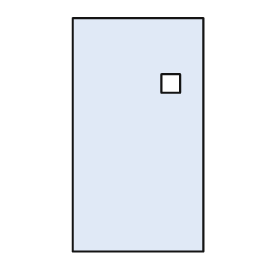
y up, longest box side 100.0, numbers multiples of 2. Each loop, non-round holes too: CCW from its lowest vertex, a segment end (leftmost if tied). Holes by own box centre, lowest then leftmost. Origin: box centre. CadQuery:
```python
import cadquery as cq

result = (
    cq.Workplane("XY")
    .moveTo(-28.0, -50.0)
    .lineTo(28.0, -50.0)
    .lineTo(28.0, 50.0)
    .lineTo(-28.0, 50.0)
    .close()
    .moveTo(10.0, 18.0)
    .lineTo(18.0, 18.0)
    .lineTo(18.0, 26.0)
    .lineTo(10.0, 26.0)
    .close()
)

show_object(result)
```